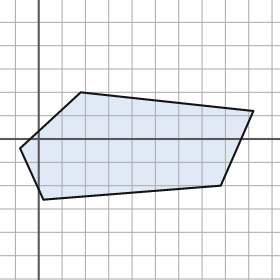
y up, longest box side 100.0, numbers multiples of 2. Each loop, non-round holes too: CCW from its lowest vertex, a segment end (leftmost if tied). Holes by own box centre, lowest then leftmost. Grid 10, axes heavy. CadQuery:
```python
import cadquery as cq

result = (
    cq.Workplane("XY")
    .moveTo(2.0, -26.0)
    .lineTo(78.0, -20.0)
    .lineTo(92.0, 12.0)
    .lineTo(18.0, 20.0)
    .lineTo(-8.0, -4.0)
    .close()
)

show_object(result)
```